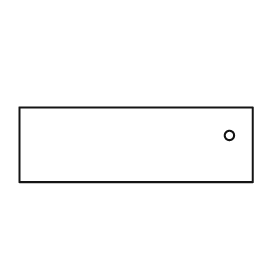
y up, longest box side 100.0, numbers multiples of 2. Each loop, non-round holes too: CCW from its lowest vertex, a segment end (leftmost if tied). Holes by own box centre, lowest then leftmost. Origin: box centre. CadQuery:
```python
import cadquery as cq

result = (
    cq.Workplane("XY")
    .moveTo(-50.0, -16.0)
    .lineTo(50.0, -16.0)
    .lineTo(50.0, 16.0)
    .lineTo(-50.0, 16.0)
    .close()
    .moveTo(40.0, 4.0)
    .circle(2.0)
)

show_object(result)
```